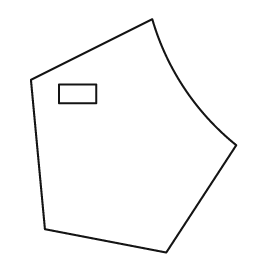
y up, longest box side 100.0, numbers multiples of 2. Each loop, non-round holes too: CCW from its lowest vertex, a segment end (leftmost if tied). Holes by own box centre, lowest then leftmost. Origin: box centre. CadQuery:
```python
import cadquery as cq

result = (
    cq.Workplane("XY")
    .moveTo(14.0, -50.0)
    .lineTo(44.0, -4.0)
    .threePointArc((22.0, 20.0), (8.0, 50.0))
    .lineTo(-44.0, 24.0)
    .lineTo(-38.0, -40.0)
    .close()
    .moveTo(-32.0, 14.0)
    .lineTo(-16.0, 14.0)
    .lineTo(-16.0, 22.0)
    .lineTo(-32.0, 22.0)
    .close()
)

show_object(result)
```